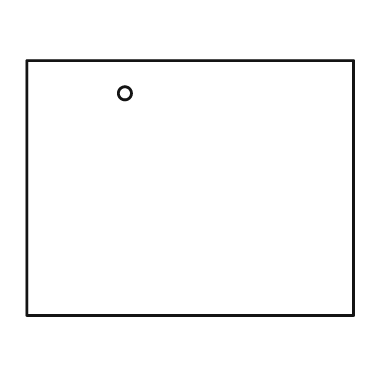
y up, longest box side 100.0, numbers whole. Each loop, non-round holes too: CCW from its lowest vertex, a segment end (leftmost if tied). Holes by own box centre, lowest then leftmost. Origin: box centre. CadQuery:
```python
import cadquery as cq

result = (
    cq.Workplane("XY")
    .moveTo(-50.0, -39.0)
    .lineTo(50.0, -39.0)
    .lineTo(50.0, 39.0)
    .lineTo(-50.0, 39.0)
    .close()
    .moveTo(-20.0, 29.0)
    .circle(2.0)
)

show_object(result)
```